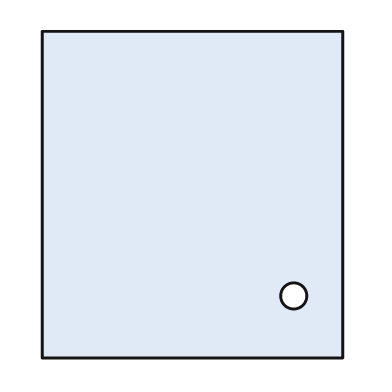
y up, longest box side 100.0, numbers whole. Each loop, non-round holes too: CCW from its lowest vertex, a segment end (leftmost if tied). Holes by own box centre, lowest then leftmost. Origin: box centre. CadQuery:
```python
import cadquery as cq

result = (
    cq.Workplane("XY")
    .moveTo(-46.0, -50.0)
    .lineTo(46.0, -50.0)
    .lineTo(46.0, 50.0)
    .lineTo(-46.0, 50.0)
    .close()
    .moveTo(31.0, -31.0)
    .circle(4.0)
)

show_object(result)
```